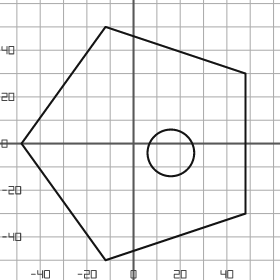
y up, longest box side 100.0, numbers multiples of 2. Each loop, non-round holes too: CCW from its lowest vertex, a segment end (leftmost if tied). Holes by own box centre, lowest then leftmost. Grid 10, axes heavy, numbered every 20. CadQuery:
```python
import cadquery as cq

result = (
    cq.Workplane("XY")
    .moveTo(-12.0, -50.0)
    .lineTo(48.0, -30.0)
    .lineTo(48.0, 30.0)
    .lineTo(-12.0, 50.0)
    .lineTo(-48.0, 0.0)
    .close()
    .moveTo(16.0, -4.0)
    .circle(10.0)
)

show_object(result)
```